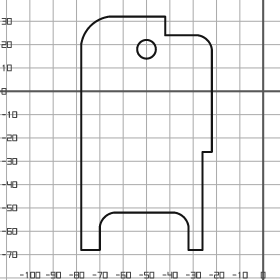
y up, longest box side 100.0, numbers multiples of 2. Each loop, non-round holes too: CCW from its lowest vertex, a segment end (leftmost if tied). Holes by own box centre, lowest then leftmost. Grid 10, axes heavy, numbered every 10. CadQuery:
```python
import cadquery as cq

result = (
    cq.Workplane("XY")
    .moveTo(-78.0, -68.0)
    .lineTo(-70.0, -68.0)
    .lineTo(-70.0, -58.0)
    .threePointArc((-68.0, -54.0), (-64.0, -52.0))
    .lineTo(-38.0, -52.0)
    .threePointArc((-34.0, -54.0), (-32.0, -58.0))
    .lineTo(-32.0, -68.0)
    .lineTo(-26.0, -68.0)
    .lineTo(-26.0, -26.0)
    .lineTo(-22.0, -26.0)
    .lineTo(-22.0, 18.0)
    .threePointArc((-24.0, 22.0), (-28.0, 24.0))
    .lineTo(-42.0, 24.0)
    .lineTo(-42.0, 32.0)
    .lineTo(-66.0, 32.0)
    .threePointArc((-74.0, 28.0), (-78.0, 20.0))
    .close()
    .moveTo(-50.0, 18.0)
    .circle(4.0)
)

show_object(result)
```